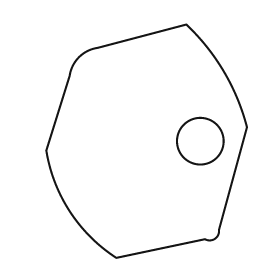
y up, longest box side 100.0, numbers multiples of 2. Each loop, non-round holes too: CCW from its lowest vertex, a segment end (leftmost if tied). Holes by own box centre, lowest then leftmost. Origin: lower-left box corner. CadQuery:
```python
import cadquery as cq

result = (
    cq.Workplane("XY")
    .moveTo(30.0, 0.0)
    .lineTo(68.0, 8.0)
    .threePointArc((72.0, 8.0), (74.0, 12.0))
    .lineTo(86.0, 56.0)
    .threePointArc((76.0, 80.0), (60.0, 100.0))
    .lineTo(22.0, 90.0)
    .threePointArc((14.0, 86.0), (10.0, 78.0))
    .lineTo(0.0, 46.0)
    .threePointArc((10.0, 20.0), (30.0, 0.0))
    .close()
    .moveTo(66.0, 50.0)
    .circle(10.0)
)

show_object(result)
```